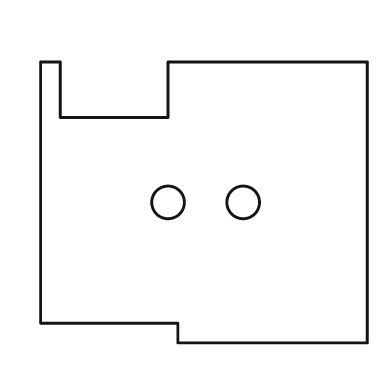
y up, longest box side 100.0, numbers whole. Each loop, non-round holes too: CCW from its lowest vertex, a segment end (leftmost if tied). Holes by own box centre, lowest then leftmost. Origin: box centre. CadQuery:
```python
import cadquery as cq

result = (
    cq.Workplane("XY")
    .moveTo(-8.0, -43.0)
    .lineTo(50.0, -43.0)
    .lineTo(50.0, 43.0)
    .lineTo(-11.0, 43.0)
    .lineTo(-11.0, 26.0)
    .lineTo(-44.0, 26.0)
    .lineTo(-44.0, 43.0)
    .lineTo(-50.0, 43.0)
    .lineTo(-50.0, -37.0)
    .lineTo(-8.0, -37.0)
    .close()
    .moveTo(-11.0, 0.0)
    .circle(5.0)
    .moveTo(12.0, 0.0)
    .circle(5.0)
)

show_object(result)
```